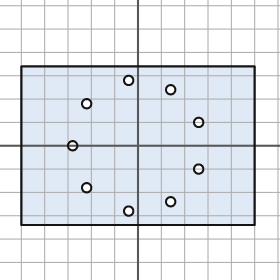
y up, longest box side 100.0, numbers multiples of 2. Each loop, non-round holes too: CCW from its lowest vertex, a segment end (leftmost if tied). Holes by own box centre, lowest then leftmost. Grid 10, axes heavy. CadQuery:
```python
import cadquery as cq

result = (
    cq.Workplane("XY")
    .moveTo(-50.0, -34.0)
    .lineTo(50.0, -34.0)
    .lineTo(50.0, 34.0)
    .lineTo(-50.0, 34.0)
    .close()
    .moveTo(-4.0, -28.0)
    .circle(2.0)
    .moveTo(14.0, -24.0)
    .circle(2.0)
    .moveTo(-22.0, -18.0)
    .circle(2.0)
    .moveTo(26.0, -10.0)
    .circle(2.0)
    .moveTo(-28.0, 0.0)
    .circle(2.0)
    .moveTo(26.0, 10.0)
    .circle(2.0)
    .moveTo(-22.0, 18.0)
    .circle(2.0)
    .moveTo(14.0, 24.0)
    .circle(2.0)
    .moveTo(-4.0, 28.0)
    .circle(2.0)
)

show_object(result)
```